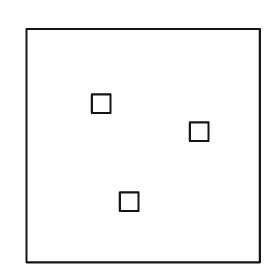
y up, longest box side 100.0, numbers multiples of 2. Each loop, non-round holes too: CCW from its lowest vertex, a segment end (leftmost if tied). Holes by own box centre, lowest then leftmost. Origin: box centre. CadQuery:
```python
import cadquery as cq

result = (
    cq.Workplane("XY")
    .moveTo(-50.0, -50.0)
    .lineTo(50.0, -50.0)
    .lineTo(50.0, 50.0)
    .lineTo(-50.0, 50.0)
    .close()
    .moveTo(-10.0, -28.0)
    .lineTo(-2.0, -28.0)
    .lineTo(-2.0, -20.0)
    .lineTo(-10.0, -20.0)
    .close()
    .moveTo(20.0, 2.0)
    .lineTo(28.0, 2.0)
    .lineTo(28.0, 10.0)
    .lineTo(20.0, 10.0)
    .close()
    .moveTo(-22.0, 14.0)
    .lineTo(-14.0, 14.0)
    .lineTo(-14.0, 22.0)
    .lineTo(-22.0, 22.0)
    .close()
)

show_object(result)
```